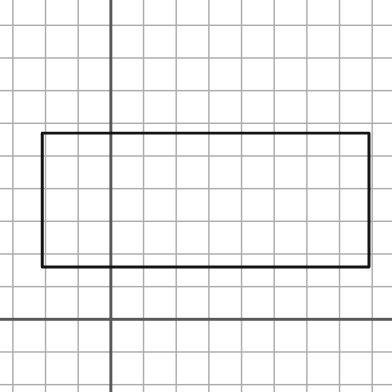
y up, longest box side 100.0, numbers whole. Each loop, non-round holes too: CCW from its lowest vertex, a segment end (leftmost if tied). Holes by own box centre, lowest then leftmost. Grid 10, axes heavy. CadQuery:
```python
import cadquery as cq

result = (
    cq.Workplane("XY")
    .moveTo(-21.0, 16.0)
    .lineTo(79.0, 16.0)
    .lineTo(79.0, 57.0)
    .lineTo(-21.0, 57.0)
    .close()
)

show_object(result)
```